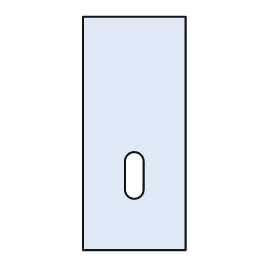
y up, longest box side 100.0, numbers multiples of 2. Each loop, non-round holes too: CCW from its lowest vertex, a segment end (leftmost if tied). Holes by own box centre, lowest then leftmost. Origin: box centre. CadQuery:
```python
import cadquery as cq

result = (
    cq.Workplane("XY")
    .moveTo(-22.0, -50.0)
    .lineTo(22.0, -50.0)
    .lineTo(22.0, 50.0)
    .lineTo(-22.0, 50.0)
    .close()
    .moveTo(-4.0, -24.0)
    .threePointArc((0.0, -28.0), (4.0, -24.0))
    .lineTo(4.0, -12.0)
    .threePointArc((0.0, -8.0), (-4.0, -12.0))
    .close()
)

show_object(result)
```